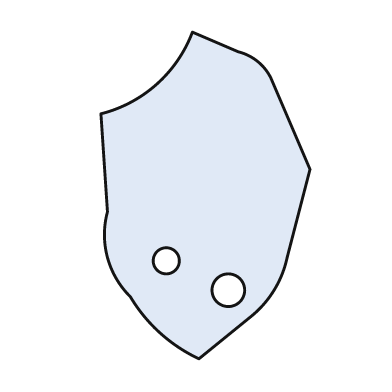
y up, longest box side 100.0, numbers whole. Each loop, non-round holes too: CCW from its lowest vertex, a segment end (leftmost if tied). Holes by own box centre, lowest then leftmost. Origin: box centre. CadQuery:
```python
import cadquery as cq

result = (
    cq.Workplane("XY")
    .moveTo(-2.0, -50.0)
    .lineTo(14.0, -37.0)
    .threePointArc((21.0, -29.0), (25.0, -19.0))
    .lineTo(32.0, 8.0)
    .lineTo(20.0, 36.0)
    .threePointArc((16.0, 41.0), (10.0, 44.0))
    .lineTo(-4.0, 50.0)
    .threePointArc((-15.0, 34.0), (-32.0, 25.0))
    .lineTo(-30.0, -5.0)
    .threePointArc((-30.0, -19.0), (-23.0, -31.0))
    .threePointArc((-14.0, -42.0), (-2.0, -50.0))
    .close()
    .moveTo(7.0, -29.0)
    .circle(5.0)
    .moveTo(-12.0, -20.0)
    .circle(4.0)
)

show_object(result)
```